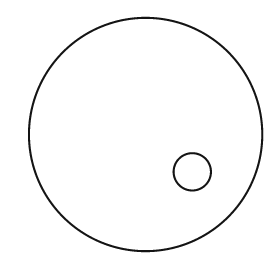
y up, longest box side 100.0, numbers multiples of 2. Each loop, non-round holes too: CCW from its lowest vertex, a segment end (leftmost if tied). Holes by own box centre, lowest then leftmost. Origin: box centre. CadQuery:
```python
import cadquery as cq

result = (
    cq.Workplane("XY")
    .moveTo(0.0, 0.0)
    .circle(50.0)
    .moveTo(20.0, -16.0)
    .circle(8.0)
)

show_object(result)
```